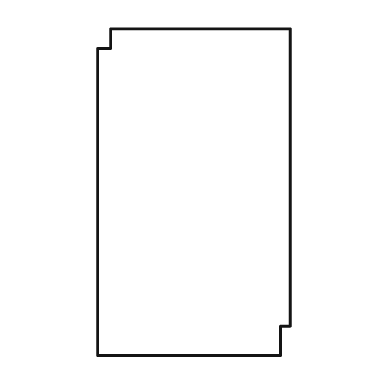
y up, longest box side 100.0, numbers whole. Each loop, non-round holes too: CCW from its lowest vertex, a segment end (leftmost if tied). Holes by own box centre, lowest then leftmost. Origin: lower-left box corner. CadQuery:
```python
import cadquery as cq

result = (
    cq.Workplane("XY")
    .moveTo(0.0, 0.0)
    .lineTo(56.0, 0.0)
    .lineTo(56.0, 9.0)
    .lineTo(59.0, 9.0)
    .lineTo(59.0, 100.0)
    .lineTo(4.0, 100.0)
    .lineTo(4.0, 94.0)
    .lineTo(0.0, 94.0)
    .close()
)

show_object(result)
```